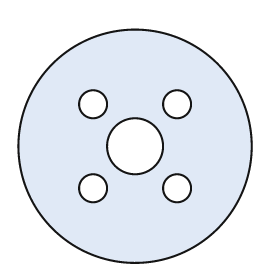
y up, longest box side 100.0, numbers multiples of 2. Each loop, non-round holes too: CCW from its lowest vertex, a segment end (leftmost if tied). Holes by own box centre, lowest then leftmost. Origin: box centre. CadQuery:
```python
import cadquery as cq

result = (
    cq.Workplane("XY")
    .moveTo(0.0, 0.0)
    .circle(50.0)
    .moveTo(-18.0, -18.0)
    .circle(6.0)
    .moveTo(18.0, -18.0)
    .circle(6.0)
    .moveTo(0.0, 0.0)
    .circle(12.0)
    .moveTo(-18.0, 18.0)
    .circle(6.0)
    .moveTo(18.0, 18.0)
    .circle(6.0)
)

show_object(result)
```